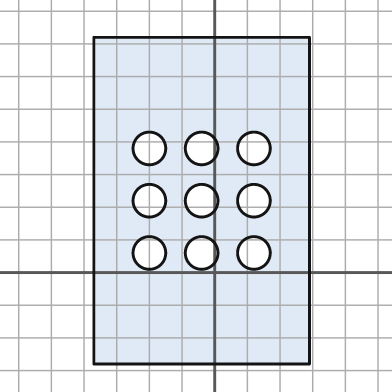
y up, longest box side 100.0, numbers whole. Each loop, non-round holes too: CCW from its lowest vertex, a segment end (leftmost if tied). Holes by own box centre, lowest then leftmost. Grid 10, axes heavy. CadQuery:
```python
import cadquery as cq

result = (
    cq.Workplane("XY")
    .moveTo(-37.0, -28.0)
    .lineTo(29.0, -28.0)
    .lineTo(29.0, 72.0)
    .lineTo(-37.0, 72.0)
    .close()
    .moveTo(-20.0, 6.0)
    .circle(5.0)
    .moveTo(-4.0, 6.0)
    .circle(5.0)
    .moveTo(12.0, 6.0)
    .circle(5.0)
    .moveTo(-20.0, 22.0)
    .circle(5.0)
    .moveTo(-4.0, 22.0)
    .circle(5.0)
    .moveTo(12.0, 22.0)
    .circle(5.0)
    .moveTo(-20.0, 38.0)
    .circle(5.0)
    .moveTo(-4.0, 38.0)
    .circle(5.0)
    .moveTo(12.0, 38.0)
    .circle(5.0)
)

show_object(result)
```